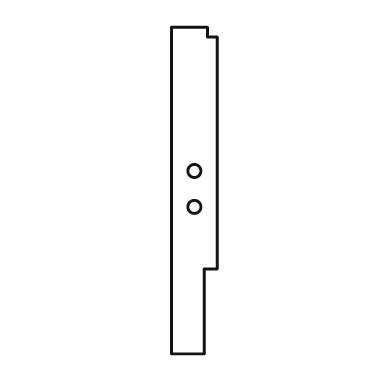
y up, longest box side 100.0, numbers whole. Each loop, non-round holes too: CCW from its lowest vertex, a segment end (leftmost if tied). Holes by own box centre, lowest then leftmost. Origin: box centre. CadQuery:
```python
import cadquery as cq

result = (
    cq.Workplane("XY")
    .moveTo(-7.0, -50.0)
    .lineTo(3.0, -50.0)
    .lineTo(3.0, -24.0)
    .lineTo(7.0, -24.0)
    .lineTo(7.0, 47.0)
    .lineTo(4.0, 47.0)
    .lineTo(4.0, 50.0)
    .lineTo(-7.0, 50.0)
    .close()
    .moveTo(0.0, -5.0)
    .circle(2.0)
    .moveTo(0.0, 6.0)
    .circle(2.0)
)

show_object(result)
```